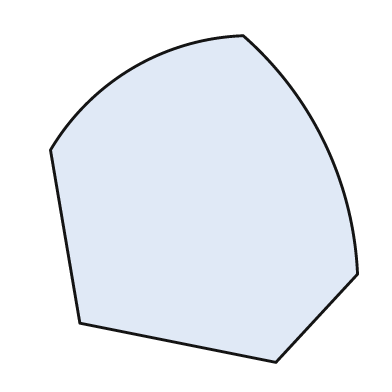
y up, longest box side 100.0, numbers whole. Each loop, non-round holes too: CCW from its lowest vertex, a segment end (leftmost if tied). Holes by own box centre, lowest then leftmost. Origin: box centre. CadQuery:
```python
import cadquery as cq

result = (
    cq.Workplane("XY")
    .moveTo(22.0, -50.0)
    .lineTo(47.0, -23.0)
    .threePointArc((37.0, 17.0), (12.0, 50.0))
    .threePointArc((-22.0, 40.0), (-47.0, 15.0))
    .lineTo(-38.0, -38.0)
    .close()
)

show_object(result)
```